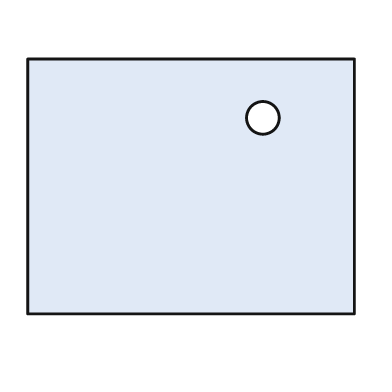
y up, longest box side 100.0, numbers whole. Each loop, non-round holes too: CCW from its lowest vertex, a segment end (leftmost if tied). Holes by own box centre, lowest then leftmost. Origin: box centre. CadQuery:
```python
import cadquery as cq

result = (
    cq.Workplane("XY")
    .moveTo(-50.0, -39.0)
    .lineTo(50.0, -39.0)
    .lineTo(50.0, 39.0)
    .lineTo(-50.0, 39.0)
    .close()
    .moveTo(22.0, 21.0)
    .circle(5.0)
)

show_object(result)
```